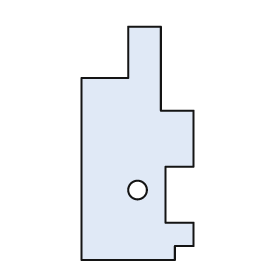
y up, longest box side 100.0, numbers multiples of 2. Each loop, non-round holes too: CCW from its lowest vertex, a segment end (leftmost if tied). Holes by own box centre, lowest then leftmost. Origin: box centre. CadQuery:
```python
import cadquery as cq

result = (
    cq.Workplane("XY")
    .moveTo(-24.0, -50.0)
    .lineTo(16.0, -50.0)
    .lineTo(16.0, -44.0)
    .lineTo(24.0, -44.0)
    .lineTo(24.0, -34.0)
    .lineTo(12.0, -34.0)
    .lineTo(12.0, -10.0)
    .lineTo(24.0, -10.0)
    .lineTo(24.0, 14.0)
    .lineTo(10.0, 14.0)
    .lineTo(10.0, 50.0)
    .lineTo(-4.0, 50.0)
    .lineTo(-4.0, 28.0)
    .lineTo(-24.0, 28.0)
    .close()
    .moveTo(0.0, -20.0)
    .circle(4.0)
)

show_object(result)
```